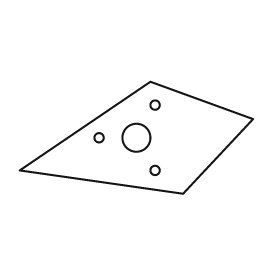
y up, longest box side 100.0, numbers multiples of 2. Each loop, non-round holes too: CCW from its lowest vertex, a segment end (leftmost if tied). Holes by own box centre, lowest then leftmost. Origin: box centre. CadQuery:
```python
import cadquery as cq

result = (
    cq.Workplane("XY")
    .moveTo(20.0, -24.0)
    .lineTo(50.0, 8.0)
    .lineTo(6.0, 24.0)
    .lineTo(-50.0, -14.0)
    .close()
    .moveTo(8.0, -14.0)
    .circle(2.0)
    .moveTo(-16.0, 0.0)
    .circle(2.0)
    .moveTo(0.0, 0.0)
    .circle(6.0)
    .moveTo(8.0, 14.0)
    .circle(2.0)
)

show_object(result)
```